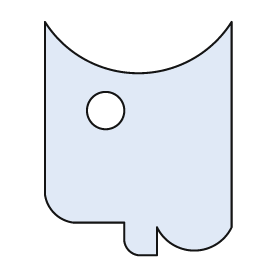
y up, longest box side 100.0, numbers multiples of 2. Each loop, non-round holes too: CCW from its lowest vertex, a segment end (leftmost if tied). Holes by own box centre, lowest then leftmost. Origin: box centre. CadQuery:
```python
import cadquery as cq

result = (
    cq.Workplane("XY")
    .moveTo(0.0, -50.0)
    .lineTo(8.0, -50.0)
    .lineTo(8.0, -38.0)
    .threePointArc((24.0, -48.0), (40.0, -38.0))
    .lineTo(40.0, 50.0)
    .threePointArc((0.0, 28.0), (-40.0, 50.0))
    .lineTo(-40.0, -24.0)
    .threePointArc((-36.0, -32.0), (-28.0, -36.0))
    .lineTo(-6.0, -36.0)
    .lineTo(-6.0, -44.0)
    .threePointArc((-4.0, -48.0), (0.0, -50.0))
    .close()
    .moveTo(-14.0, 12.0)
    .circle(8.0)
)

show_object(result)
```